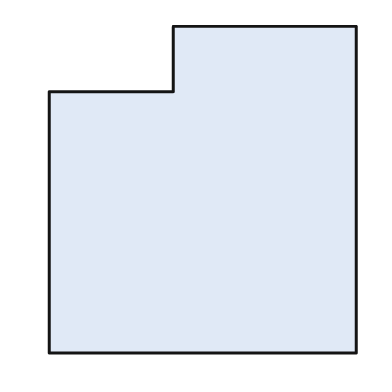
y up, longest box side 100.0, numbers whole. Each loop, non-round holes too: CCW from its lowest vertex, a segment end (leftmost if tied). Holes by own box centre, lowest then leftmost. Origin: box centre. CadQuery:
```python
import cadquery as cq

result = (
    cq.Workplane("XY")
    .moveTo(-47.0, -50.0)
    .lineTo(47.0, -50.0)
    .lineTo(47.0, 50.0)
    .lineTo(-9.0, 50.0)
    .lineTo(-9.0, 30.0)
    .lineTo(-47.0, 30.0)
    .close()
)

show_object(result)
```